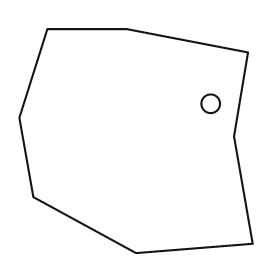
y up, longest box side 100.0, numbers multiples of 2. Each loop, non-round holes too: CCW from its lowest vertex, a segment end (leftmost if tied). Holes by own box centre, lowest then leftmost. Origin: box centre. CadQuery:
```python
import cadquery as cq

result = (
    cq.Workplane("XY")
    .moveTo(0.0, -48.0)
    .lineTo(50.0, -44.0)
    .lineTo(42.0, 2.0)
    .lineTo(48.0, 38.0)
    .lineTo(-4.0, 48.0)
    .lineTo(-38.0, 48.0)
    .lineTo(-50.0, 10.0)
    .lineTo(-44.0, -24.0)
    .close()
    .moveTo(32.0, 16.0)
    .circle(4.0)
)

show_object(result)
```